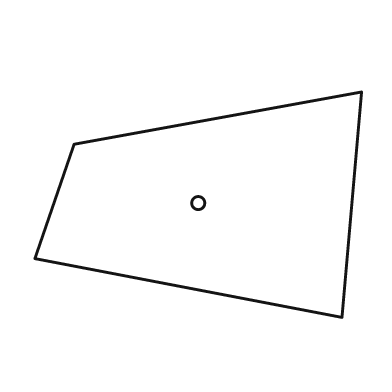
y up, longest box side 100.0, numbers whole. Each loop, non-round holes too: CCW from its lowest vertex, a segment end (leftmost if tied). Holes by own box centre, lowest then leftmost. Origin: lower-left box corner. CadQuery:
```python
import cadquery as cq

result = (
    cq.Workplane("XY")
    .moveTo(94.0, 0.0)
    .lineTo(100.0, 69.0)
    .lineTo(12.0, 53.0)
    .lineTo(0.0, 18.0)
    .close()
    .moveTo(50.0, 35.0)
    .circle(2.0)
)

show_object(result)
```